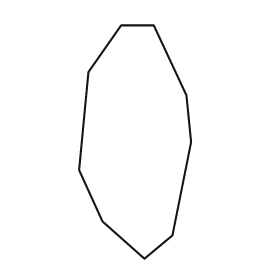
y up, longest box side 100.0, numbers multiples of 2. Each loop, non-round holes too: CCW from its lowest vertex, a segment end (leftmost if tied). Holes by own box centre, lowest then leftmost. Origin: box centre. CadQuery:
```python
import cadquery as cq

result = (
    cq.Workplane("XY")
    .moveTo(4.0, -50.0)
    .lineTo(16.0, -40.0)
    .lineTo(24.0, 0.0)
    .lineTo(22.0, 20.0)
    .lineTo(8.0, 50.0)
    .lineTo(-6.0, 50.0)
    .lineTo(-20.0, 30.0)
    .lineTo(-24.0, -12.0)
    .lineTo(-14.0, -34.0)
    .close()
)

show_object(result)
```